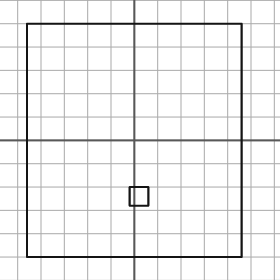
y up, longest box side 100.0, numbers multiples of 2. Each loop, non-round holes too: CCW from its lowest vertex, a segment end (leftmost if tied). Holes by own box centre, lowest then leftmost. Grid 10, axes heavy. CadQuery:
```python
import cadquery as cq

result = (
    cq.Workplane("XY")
    .moveTo(-46.0, -50.0)
    .lineTo(46.0, -50.0)
    .lineTo(46.0, 50.0)
    .lineTo(-46.0, 50.0)
    .close()
    .moveTo(-2.0, -28.0)
    .lineTo(6.0, -28.0)
    .lineTo(6.0, -20.0)
    .lineTo(-2.0, -20.0)
    .close()
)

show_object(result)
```